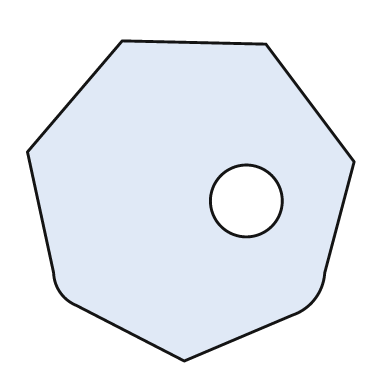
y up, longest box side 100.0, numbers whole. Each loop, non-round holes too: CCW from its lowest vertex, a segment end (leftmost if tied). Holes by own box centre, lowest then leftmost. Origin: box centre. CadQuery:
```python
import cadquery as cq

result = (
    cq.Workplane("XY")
    .moveTo(-2.0, -49.0)
    .lineTo(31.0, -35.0)
    .threePointArc((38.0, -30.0), (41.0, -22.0))
    .lineTo(50.0, 12.0)
    .lineTo(23.0, 48.0)
    .lineTo(-21.0, 49.0)
    .lineTo(-50.0, 15.0)
    .lineTo(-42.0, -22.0)
    .threePointArc((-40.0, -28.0), (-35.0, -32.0))
    .close()
    .moveTo(17.0, 0.0)
    .circle(11.0)
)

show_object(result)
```